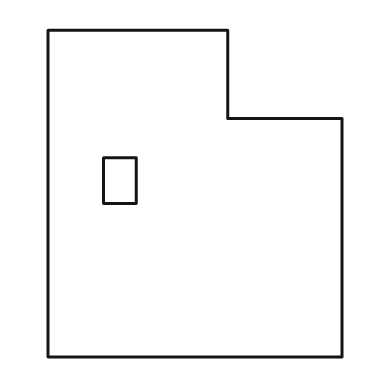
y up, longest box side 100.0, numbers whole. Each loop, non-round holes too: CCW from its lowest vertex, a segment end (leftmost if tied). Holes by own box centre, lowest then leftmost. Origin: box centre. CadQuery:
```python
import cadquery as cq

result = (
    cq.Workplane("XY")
    .moveTo(-45.0, -50.0)
    .lineTo(45.0, -50.0)
    .lineTo(45.0, 23.0)
    .lineTo(10.0, 23.0)
    .lineTo(10.0, 50.0)
    .lineTo(-45.0, 50.0)
    .close()
    .moveTo(-28.0, -3.0)
    .lineTo(-18.0, -3.0)
    .lineTo(-18.0, 11.0)
    .lineTo(-28.0, 11.0)
    .close()
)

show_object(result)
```